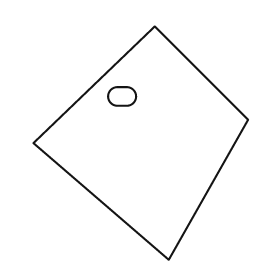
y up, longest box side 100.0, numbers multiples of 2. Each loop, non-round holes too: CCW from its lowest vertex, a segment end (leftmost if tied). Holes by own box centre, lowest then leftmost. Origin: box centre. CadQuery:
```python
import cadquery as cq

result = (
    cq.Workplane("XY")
    .moveTo(12.0, -50.0)
    .lineTo(46.0, 10.0)
    .lineTo(6.0, 50.0)
    .lineTo(-46.0, 0.0)
    .close()
    .moveTo(-10.0, 16.0)
    .lineTo(-6.0, 16.0)
    .threePointArc((-2.0, 20.0), (-6.0, 24.0))
    .lineTo(-10.0, 24.0)
    .threePointArc((-14.0, 20.0), (-10.0, 16.0))
    .close()
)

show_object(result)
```